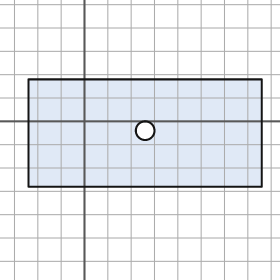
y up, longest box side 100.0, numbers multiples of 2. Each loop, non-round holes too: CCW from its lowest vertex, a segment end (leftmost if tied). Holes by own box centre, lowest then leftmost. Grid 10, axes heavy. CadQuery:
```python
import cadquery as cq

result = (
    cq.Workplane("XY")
    .moveTo(-24.0, -28.0)
    .lineTo(76.0, -28.0)
    .lineTo(76.0, 18.0)
    .lineTo(-24.0, 18.0)
    .close()
    .moveTo(26.0, -4.0)
    .circle(4.0)
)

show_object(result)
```